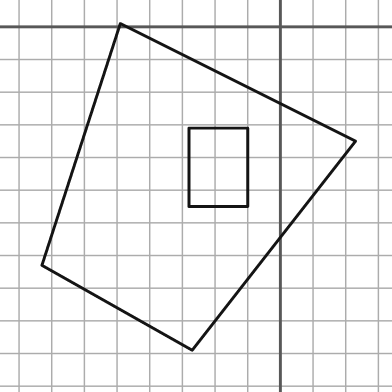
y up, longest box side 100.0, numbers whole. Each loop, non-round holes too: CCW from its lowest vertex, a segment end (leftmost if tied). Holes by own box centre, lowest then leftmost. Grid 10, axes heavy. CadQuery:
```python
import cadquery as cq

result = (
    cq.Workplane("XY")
    .moveTo(-27.0, -99.0)
    .lineTo(23.0, -35.0)
    .lineTo(-49.0, 1.0)
    .lineTo(-73.0, -73.0)
    .close()
    .moveTo(-28.0, -55.0)
    .lineTo(-10.0, -55.0)
    .lineTo(-10.0, -31.0)
    .lineTo(-28.0, -31.0)
    .close()
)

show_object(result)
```